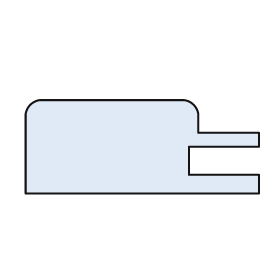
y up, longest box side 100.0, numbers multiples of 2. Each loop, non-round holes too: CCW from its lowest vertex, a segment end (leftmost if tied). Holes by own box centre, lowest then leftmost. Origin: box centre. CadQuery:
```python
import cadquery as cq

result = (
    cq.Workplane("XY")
    .moveTo(-50.0, -20.0)
    .lineTo(50.0, -20.0)
    .lineTo(50.0, -12.0)
    .lineTo(20.0, -12.0)
    .lineTo(20.0, 0.0)
    .lineTo(50.0, 0.0)
    .lineTo(50.0, 6.0)
    .lineTo(24.0, 6.0)
    .lineTo(24.0, 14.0)
    .threePointArc((22.0, 18.0), (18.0, 20.0))
    .lineTo(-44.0, 20.0)
    .threePointArc((-48.0, 18.0), (-50.0, 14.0))
    .close()
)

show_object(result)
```